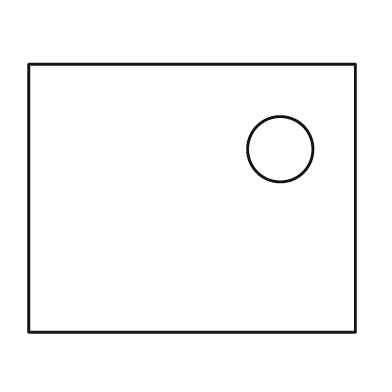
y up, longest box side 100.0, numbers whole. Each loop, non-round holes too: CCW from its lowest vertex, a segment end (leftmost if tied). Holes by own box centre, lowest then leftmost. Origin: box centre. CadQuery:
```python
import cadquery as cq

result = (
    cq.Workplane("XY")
    .moveTo(-50.0, -41.0)
    .lineTo(50.0, -41.0)
    .lineTo(50.0, 41.0)
    .lineTo(-50.0, 41.0)
    .close()
    .moveTo(27.0, 15.0)
    .circle(10.0)
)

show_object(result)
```